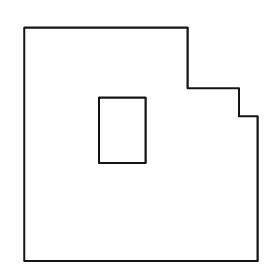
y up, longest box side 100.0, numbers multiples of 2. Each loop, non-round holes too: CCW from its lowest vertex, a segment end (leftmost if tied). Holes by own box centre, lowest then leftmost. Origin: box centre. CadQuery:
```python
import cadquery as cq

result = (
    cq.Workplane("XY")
    .moveTo(-50.0, -50.0)
    .lineTo(50.0, -50.0)
    .lineTo(50.0, 12.0)
    .lineTo(42.0, 12.0)
    .lineTo(42.0, 24.0)
    .lineTo(20.0, 24.0)
    .lineTo(20.0, 50.0)
    .lineTo(-50.0, 50.0)
    .close()
    .moveTo(-18.0, -8.0)
    .lineTo(2.0, -8.0)
    .lineTo(2.0, 20.0)
    .lineTo(-18.0, 20.0)
    .close()
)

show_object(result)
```